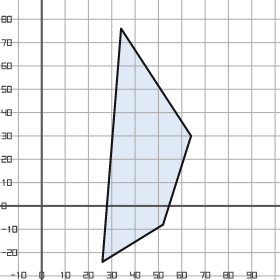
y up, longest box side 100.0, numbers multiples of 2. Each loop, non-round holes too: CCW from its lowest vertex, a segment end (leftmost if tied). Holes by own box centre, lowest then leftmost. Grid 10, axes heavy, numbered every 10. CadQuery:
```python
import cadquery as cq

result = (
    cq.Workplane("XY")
    .moveTo(26.0, -24.0)
    .lineTo(52.0, -8.0)
    .lineTo(64.0, 30.0)
    .lineTo(34.0, 76.0)
    .close()
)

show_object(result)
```